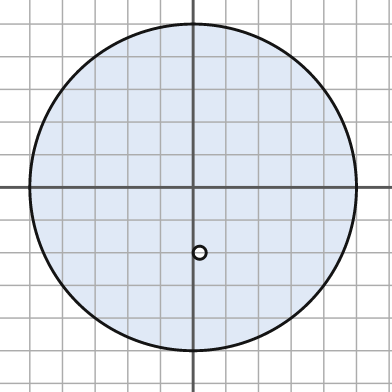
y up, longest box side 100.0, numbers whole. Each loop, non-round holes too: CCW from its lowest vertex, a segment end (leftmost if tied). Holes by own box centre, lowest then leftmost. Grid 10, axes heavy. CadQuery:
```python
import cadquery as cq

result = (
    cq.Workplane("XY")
    .moveTo(0.0, 0.0)
    .circle(50.0)
    .moveTo(2.0, -20.0)
    .circle(2.0)
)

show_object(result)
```